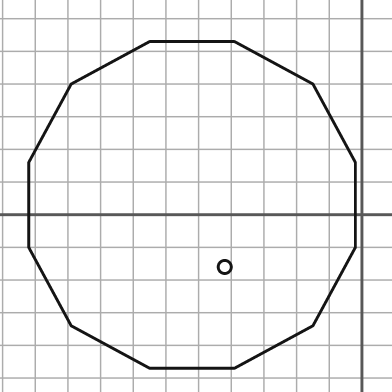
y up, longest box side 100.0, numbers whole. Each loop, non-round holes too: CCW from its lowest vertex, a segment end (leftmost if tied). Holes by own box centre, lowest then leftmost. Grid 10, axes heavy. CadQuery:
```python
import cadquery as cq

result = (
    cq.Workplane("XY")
    .moveTo(-65.0, -47.0)
    .lineTo(-39.0, -47.0)
    .lineTo(-15.0, -34.0)
    .lineTo(-2.0, -10.0)
    .lineTo(-2.0, 16.0)
    .lineTo(-15.0, 40.0)
    .lineTo(-39.0, 53.0)
    .lineTo(-65.0, 53.0)
    .lineTo(-89.0, 40.0)
    .lineTo(-102.0, 16.0)
    .lineTo(-102.0, -10.0)
    .lineTo(-89.0, -34.0)
    .close()
    .moveTo(-42.0, -16.0)
    .circle(2.0)
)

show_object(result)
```